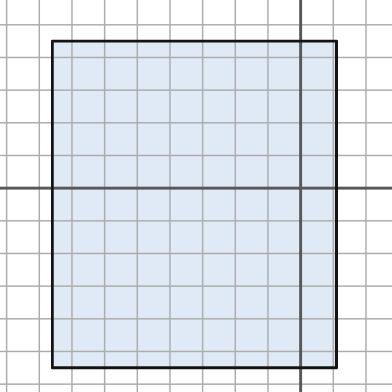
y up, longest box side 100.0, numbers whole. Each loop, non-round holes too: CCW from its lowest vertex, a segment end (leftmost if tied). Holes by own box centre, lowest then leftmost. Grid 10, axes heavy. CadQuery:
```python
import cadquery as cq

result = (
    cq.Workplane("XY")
    .moveTo(-76.0, -55.0)
    .lineTo(11.0, -55.0)
    .lineTo(11.0, 45.0)
    .lineTo(-76.0, 45.0)
    .close()
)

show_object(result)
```